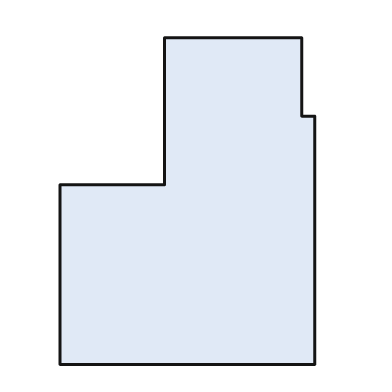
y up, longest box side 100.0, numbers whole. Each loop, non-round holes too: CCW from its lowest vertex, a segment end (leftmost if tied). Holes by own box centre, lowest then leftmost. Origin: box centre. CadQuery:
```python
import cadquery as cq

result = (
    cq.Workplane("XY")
    .moveTo(-39.0, -50.0)
    .lineTo(39.0, -50.0)
    .lineTo(39.0, 26.0)
    .lineTo(35.0, 26.0)
    .lineTo(35.0, 50.0)
    .lineTo(-7.0, 50.0)
    .lineTo(-7.0, 5.0)
    .lineTo(-39.0, 5.0)
    .close()
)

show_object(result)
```